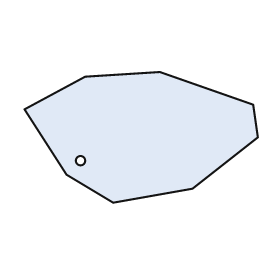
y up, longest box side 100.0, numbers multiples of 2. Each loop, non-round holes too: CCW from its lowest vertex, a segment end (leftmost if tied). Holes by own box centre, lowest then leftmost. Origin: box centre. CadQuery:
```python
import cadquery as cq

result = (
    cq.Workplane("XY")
    .moveTo(-12.0, -28.0)
    .lineTo(22.0, -22.0)
    .lineTo(50.0, 0.0)
    .lineTo(48.0, 14.0)
    .lineTo(8.0, 28.0)
    .lineTo(-24.0, 26.0)
    .lineTo(-50.0, 12.0)
    .lineTo(-32.0, -16.0)
    .close()
    .moveTo(-26.0, -10.0)
    .circle(2.0)
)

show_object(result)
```